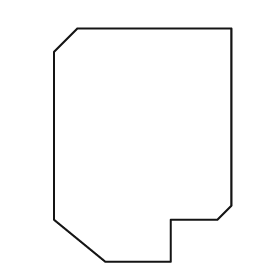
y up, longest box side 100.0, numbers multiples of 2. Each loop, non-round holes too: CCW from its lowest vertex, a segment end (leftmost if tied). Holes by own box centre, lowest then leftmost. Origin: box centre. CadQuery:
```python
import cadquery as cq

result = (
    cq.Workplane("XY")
    .moveTo(-16.0, -50.0)
    .lineTo(12.0, -50.0)
    .lineTo(12.0, -32.0)
    .lineTo(32.0, -32.0)
    .lineTo(38.0, -26.0)
    .lineTo(38.0, 50.0)
    .lineTo(-28.0, 50.0)
    .lineTo(-38.0, 40.0)
    .lineTo(-38.0, -32.0)
    .close()
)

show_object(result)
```